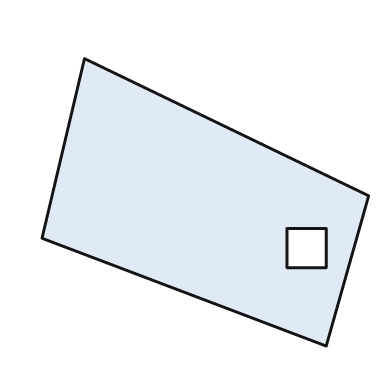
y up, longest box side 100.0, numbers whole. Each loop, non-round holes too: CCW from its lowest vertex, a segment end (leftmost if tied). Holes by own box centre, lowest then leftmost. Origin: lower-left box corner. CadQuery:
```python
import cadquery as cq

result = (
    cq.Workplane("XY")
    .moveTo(87.0, 0.0)
    .lineTo(100.0, 46.0)
    .lineTo(13.0, 88.0)
    .lineTo(0.0, 33.0)
    .close()
    .moveTo(75.0, 24.0)
    .lineTo(87.0, 24.0)
    .lineTo(87.0, 36.0)
    .lineTo(75.0, 36.0)
    .close()
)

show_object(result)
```